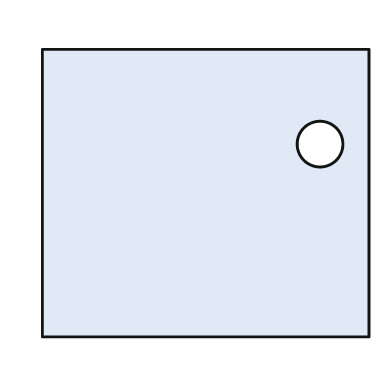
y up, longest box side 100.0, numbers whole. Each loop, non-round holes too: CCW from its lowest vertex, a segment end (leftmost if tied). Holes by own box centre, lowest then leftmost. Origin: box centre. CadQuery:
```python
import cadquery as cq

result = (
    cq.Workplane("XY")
    .moveTo(-50.0, -44.0)
    .lineTo(50.0, -44.0)
    .lineTo(50.0, 44.0)
    .lineTo(-50.0, 44.0)
    .close()
    .moveTo(35.0, 15.0)
    .circle(7.0)
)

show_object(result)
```